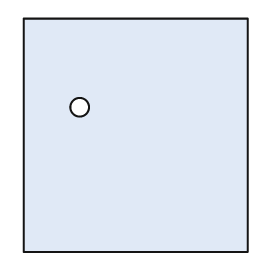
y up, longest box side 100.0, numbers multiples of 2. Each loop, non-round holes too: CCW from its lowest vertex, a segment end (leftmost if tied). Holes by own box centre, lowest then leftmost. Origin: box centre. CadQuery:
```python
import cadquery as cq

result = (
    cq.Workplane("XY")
    .moveTo(-48.0, -50.0)
    .lineTo(48.0, -50.0)
    .lineTo(48.0, 50.0)
    .lineTo(-48.0, 50.0)
    .close()
    .moveTo(-24.0, 12.0)
    .circle(4.0)
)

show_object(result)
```